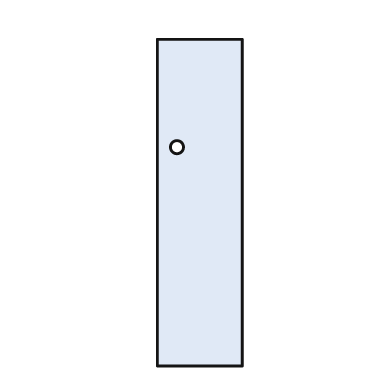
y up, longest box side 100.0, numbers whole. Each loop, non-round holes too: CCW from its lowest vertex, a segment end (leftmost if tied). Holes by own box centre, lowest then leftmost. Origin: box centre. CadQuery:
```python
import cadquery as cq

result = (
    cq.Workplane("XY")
    .moveTo(-13.0, -50.0)
    .lineTo(13.0, -50.0)
    .lineTo(13.0, 50.0)
    .lineTo(-13.0, 50.0)
    .close()
    .moveTo(-7.0, 17.0)
    .circle(2.0)
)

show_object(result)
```